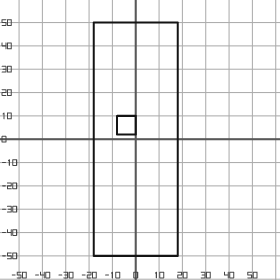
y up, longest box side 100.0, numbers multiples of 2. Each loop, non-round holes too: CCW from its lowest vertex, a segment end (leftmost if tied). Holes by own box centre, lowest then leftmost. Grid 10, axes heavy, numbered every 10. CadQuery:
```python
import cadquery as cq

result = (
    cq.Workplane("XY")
    .moveTo(-18.0, -50.0)
    .lineTo(18.0, -50.0)
    .lineTo(18.0, 50.0)
    .lineTo(-18.0, 50.0)
    .close()
    .moveTo(-8.0, 2.0)
    .lineTo(0.0, 2.0)
    .lineTo(0.0, 10.0)
    .lineTo(-8.0, 10.0)
    .close()
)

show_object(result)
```